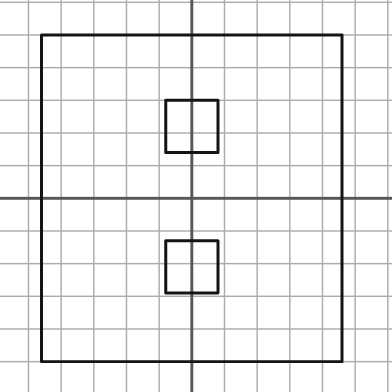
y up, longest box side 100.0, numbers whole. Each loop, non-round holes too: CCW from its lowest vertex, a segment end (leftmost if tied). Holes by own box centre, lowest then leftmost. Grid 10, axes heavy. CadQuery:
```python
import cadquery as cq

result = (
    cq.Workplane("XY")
    .moveTo(-46.0, -50.0)
    .lineTo(46.0, -50.0)
    .lineTo(46.0, 50.0)
    .lineTo(-46.0, 50.0)
    .close()
    .moveTo(-8.0, -29.0)
    .lineTo(8.0, -29.0)
    .lineTo(8.0, -13.0)
    .lineTo(-8.0, -13.0)
    .close()
    .moveTo(-8.0, 14.0)
    .lineTo(8.0, 14.0)
    .lineTo(8.0, 30.0)
    .lineTo(-8.0, 30.0)
    .close()
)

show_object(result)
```